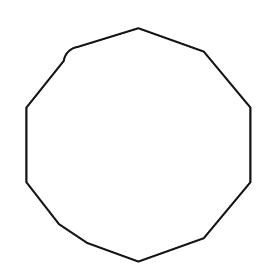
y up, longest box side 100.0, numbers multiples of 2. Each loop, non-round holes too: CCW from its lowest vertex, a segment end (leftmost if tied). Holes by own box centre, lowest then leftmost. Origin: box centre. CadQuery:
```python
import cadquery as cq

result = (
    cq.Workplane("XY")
    .moveTo(0.0, -50.0)
    .lineTo(28.0, -40.0)
    .lineTo(48.0, -16.0)
    .lineTo(48.0, 16.0)
    .lineTo(28.0, 40.0)
    .lineTo(0.0, 50.0)
    .lineTo(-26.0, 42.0)
    .threePointArc((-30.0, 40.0), (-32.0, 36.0))
    .lineTo(-48.0, 16.0)
    .lineTo(-48.0, -16.0)
    .lineTo(-34.0, -34.0)
    .lineTo(-22.0, -42.0)
    .close()
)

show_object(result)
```